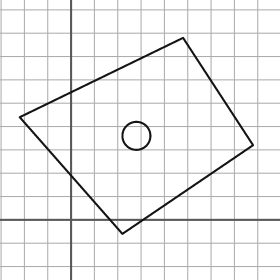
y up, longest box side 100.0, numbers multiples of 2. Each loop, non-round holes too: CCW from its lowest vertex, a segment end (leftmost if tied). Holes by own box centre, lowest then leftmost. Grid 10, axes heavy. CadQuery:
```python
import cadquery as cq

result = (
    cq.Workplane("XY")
    .moveTo(22.0, -6.0)
    .lineTo(78.0, 32.0)
    .lineTo(48.0, 78.0)
    .lineTo(-22.0, 44.0)
    .close()
    .moveTo(28.0, 36.0)
    .circle(6.0)
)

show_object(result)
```